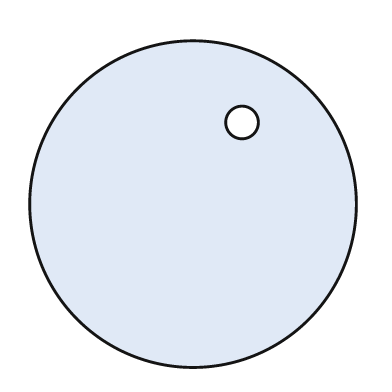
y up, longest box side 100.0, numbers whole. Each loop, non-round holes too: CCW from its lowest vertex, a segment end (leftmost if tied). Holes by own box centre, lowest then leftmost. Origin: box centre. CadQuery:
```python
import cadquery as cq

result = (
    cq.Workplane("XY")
    .moveTo(0.0, 0.0)
    .circle(50.0)
    .moveTo(15.0, 25.0)
    .circle(5.0)
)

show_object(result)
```